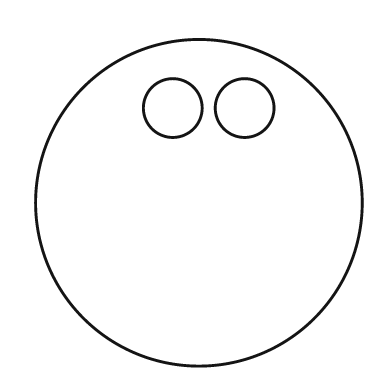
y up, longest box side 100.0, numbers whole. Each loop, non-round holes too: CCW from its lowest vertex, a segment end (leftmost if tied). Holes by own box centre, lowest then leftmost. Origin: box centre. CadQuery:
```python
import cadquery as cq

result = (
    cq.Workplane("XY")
    .moveTo(0.0, 0.0)
    .circle(50.0)
    .moveTo(-8.0, 29.0)
    .circle(9.0)
    .moveTo(14.0, 29.0)
    .circle(9.0)
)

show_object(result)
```